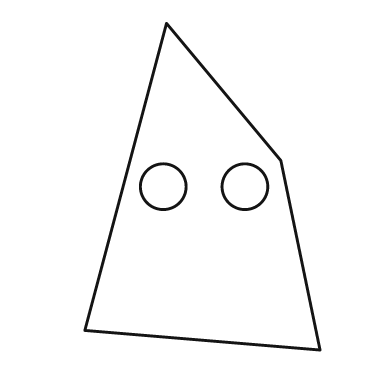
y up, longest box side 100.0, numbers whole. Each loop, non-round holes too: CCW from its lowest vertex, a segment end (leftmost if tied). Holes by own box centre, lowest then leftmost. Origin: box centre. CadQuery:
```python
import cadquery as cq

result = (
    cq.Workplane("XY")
    .moveTo(36.0, -50.0)
    .lineTo(24.0, 8.0)
    .lineTo(-11.0, 50.0)
    .lineTo(-36.0, -44.0)
    .close()
    .moveTo(-12.0, 0.0)
    .circle(7.0)
    .moveTo(13.0, 0.0)
    .circle(7.0)
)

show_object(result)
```